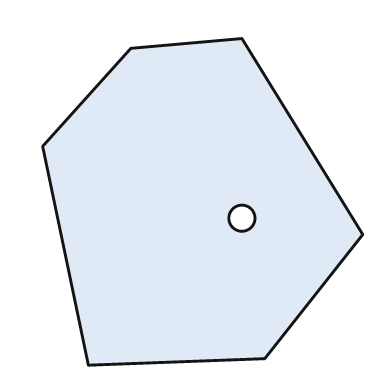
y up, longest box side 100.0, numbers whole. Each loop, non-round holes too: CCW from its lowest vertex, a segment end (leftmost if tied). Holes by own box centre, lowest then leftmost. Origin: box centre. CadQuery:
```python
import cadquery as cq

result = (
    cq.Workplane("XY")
    .moveTo(-35.0, -50.0)
    .lineTo(19.0, -48.0)
    .lineTo(49.0, -10.0)
    .lineTo(12.0, 50.0)
    .lineTo(-22.0, 47.0)
    .lineTo(-49.0, 17.0)
    .close()
    .moveTo(12.0, -5.0)
    .circle(4.0)
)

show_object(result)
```